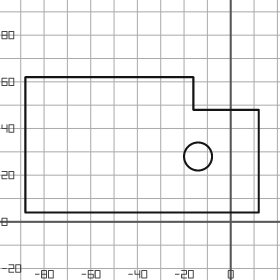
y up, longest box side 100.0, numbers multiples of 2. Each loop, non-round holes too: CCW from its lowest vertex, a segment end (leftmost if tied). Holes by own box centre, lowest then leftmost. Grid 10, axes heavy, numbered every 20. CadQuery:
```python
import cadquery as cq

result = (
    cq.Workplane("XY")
    .moveTo(-88.0, 4.0)
    .lineTo(12.0, 4.0)
    .lineTo(12.0, 48.0)
    .lineTo(-16.0, 48.0)
    .lineTo(-16.0, 62.0)
    .lineTo(-88.0, 62.0)
    .close()
    .moveTo(-14.0, 28.0)
    .circle(6.0)
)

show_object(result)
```